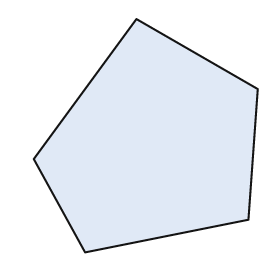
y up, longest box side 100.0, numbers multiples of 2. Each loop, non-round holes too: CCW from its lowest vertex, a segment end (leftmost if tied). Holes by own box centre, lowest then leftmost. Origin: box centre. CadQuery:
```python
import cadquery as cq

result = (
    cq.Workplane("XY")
    .moveTo(-26.0, -50.0)
    .lineTo(44.0, -36.0)
    .lineTo(48.0, 20.0)
    .lineTo(-4.0, 50.0)
    .lineTo(-48.0, -10.0)
    .close()
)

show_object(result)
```